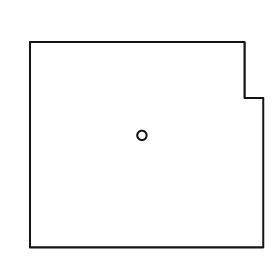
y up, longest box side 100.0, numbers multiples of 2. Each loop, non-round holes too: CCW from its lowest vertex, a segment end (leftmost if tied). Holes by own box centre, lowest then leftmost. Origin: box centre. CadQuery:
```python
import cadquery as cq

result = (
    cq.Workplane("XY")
    .moveTo(-50.0, -44.0)
    .lineTo(50.0, -44.0)
    .lineTo(50.0, 20.0)
    .lineTo(42.0, 20.0)
    .lineTo(42.0, 44.0)
    .lineTo(-50.0, 44.0)
    .close()
    .moveTo(-2.0, 4.0)
    .circle(2.0)
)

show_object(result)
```